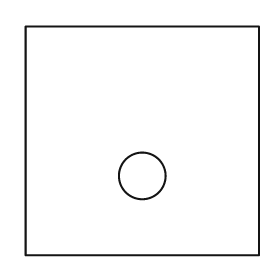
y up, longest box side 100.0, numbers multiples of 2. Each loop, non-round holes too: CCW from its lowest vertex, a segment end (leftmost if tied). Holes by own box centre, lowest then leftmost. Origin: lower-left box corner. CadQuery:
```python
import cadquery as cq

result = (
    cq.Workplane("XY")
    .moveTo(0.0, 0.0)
    .lineTo(100.0, 0.0)
    .lineTo(100.0, 98.0)
    .lineTo(0.0, 98.0)
    .close()
    .moveTo(50.0, 34.0)
    .circle(10.0)
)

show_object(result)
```